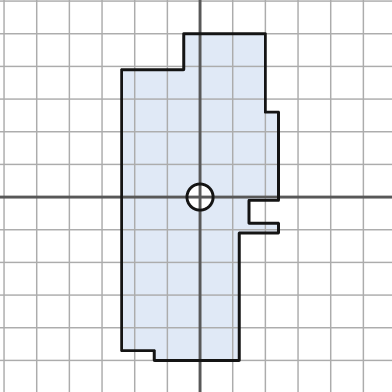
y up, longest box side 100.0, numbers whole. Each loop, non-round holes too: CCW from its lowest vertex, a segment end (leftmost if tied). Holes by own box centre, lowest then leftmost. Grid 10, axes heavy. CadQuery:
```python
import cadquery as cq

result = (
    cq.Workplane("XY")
    .moveTo(-14.0, -50.0)
    .lineTo(12.0, -50.0)
    .lineTo(12.0, -11.0)
    .lineTo(24.0, -11.0)
    .lineTo(24.0, -8.0)
    .lineTo(15.0, -8.0)
    .lineTo(15.0, -1.0)
    .lineTo(24.0, -1.0)
    .lineTo(24.0, 26.0)
    .lineTo(20.0, 26.0)
    .lineTo(20.0, 50.0)
    .lineTo(-5.0, 50.0)
    .lineTo(-5.0, 39.0)
    .lineTo(-24.0, 39.0)
    .lineTo(-24.0, -47.0)
    .lineTo(-14.0, -47.0)
    .close()
    .moveTo(0.0, 0.0)
    .circle(4.0)
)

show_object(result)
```